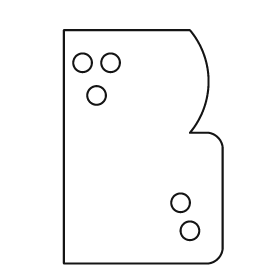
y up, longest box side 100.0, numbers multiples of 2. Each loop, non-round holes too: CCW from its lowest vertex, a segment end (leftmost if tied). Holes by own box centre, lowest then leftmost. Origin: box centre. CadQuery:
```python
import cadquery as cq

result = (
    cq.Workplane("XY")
    .moveTo(-34.0, -50.0)
    .lineTo(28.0, -50.0)
    .threePointArc((32.0, -48.0), (34.0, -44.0))
    .lineTo(34.0, 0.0)
    .threePointArc((32.0, 4.0), (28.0, 6.0))
    .lineTo(20.0, 6.0)
    .threePointArc((28.0, 28.0), (20.0, 50.0))
    .lineTo(-34.0, 50.0)
    .close()
    .moveTo(20.0, -36.0)
    .circle(4.0)
    .moveTo(16.0, -24.0)
    .circle(4.0)
    .moveTo(-20.0, 22.0)
    .circle(4.0)
    .moveTo(-26.0, 36.0)
    .circle(4.0)
    .moveTo(-14.0, 36.0)
    .circle(4.0)
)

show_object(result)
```